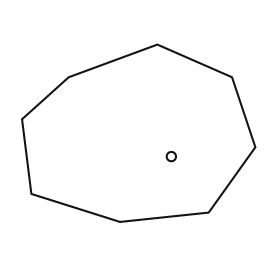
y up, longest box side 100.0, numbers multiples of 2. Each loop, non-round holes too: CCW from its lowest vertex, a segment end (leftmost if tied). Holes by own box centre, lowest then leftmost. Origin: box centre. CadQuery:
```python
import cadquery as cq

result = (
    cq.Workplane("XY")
    .moveTo(-8.0, -38.0)
    .lineTo(30.0, -34.0)
    .lineTo(50.0, -6.0)
    .lineTo(40.0, 24.0)
    .lineTo(8.0, 38.0)
    .lineTo(-30.0, 24.0)
    .lineTo(-50.0, 6.0)
    .lineTo(-46.0, -26.0)
    .close()
    .moveTo(14.0, -10.0)
    .circle(2.0)
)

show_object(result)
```